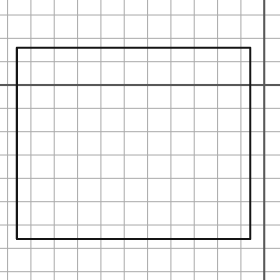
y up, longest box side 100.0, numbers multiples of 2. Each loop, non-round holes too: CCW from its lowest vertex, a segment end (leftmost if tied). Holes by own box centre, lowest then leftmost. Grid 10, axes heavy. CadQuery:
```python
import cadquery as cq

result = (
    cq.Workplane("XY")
    .moveTo(-106.0, -66.0)
    .lineTo(-6.0, -66.0)
    .lineTo(-6.0, 16.0)
    .lineTo(-106.0, 16.0)
    .close()
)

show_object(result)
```